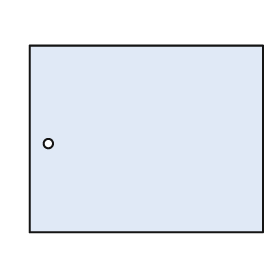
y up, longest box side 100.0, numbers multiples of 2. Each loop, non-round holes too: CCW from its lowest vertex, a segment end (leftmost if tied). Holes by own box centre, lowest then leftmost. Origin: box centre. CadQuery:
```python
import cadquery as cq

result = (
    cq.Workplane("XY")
    .moveTo(-50.0, -40.0)
    .lineTo(50.0, -40.0)
    .lineTo(50.0, 40.0)
    .lineTo(-50.0, 40.0)
    .close()
    .moveTo(-42.0, -2.0)
    .circle(2.0)
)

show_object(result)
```